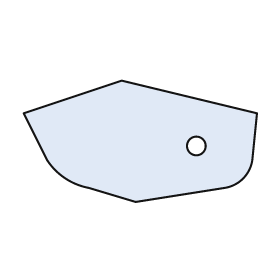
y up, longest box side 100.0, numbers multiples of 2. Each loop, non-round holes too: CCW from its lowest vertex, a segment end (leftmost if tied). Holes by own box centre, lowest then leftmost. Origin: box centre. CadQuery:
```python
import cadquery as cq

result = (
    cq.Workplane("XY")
    .moveTo(-2.0, -26.0)
    .lineTo(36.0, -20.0)
    .threePointArc((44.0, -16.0), (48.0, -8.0))
    .lineTo(50.0, 12.0)
    .lineTo(-8.0, 26.0)
    .lineTo(-50.0, 12.0)
    .lineTo(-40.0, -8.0)
    .threePointArc((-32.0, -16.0), (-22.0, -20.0))
    .close()
    .moveTo(24.0, -2.0)
    .circle(4.0)
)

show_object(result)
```